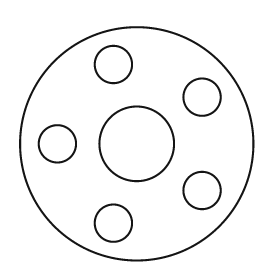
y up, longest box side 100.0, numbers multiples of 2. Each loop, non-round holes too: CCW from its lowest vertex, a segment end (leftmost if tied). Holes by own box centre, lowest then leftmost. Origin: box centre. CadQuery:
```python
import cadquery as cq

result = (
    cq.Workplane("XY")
    .moveTo(0.0, 0.0)
    .circle(50.0)
    .moveTo(-10.0, -34.0)
    .circle(8.0)
    .moveTo(28.0, -20.0)
    .circle(8.0)
    .moveTo(-34.0, 0.0)
    .circle(8.0)
    .moveTo(0.0, 0.0)
    .circle(16.0)
    .moveTo(28.0, 20.0)
    .circle(8.0)
    .moveTo(-10.0, 34.0)
    .circle(8.0)
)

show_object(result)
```